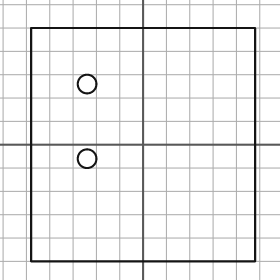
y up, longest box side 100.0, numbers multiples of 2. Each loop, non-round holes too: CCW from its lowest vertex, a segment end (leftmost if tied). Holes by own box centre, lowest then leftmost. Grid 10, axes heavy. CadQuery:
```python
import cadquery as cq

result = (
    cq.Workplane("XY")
    .moveTo(-48.0, -50.0)
    .lineTo(48.0, -50.0)
    .lineTo(48.0, 50.0)
    .lineTo(-48.0, 50.0)
    .close()
    .moveTo(-24.0, -6.0)
    .circle(4.0)
    .moveTo(-24.0, 26.0)
    .circle(4.0)
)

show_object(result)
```